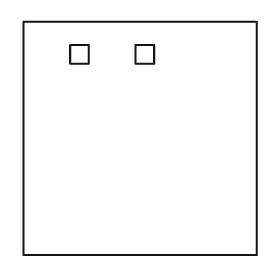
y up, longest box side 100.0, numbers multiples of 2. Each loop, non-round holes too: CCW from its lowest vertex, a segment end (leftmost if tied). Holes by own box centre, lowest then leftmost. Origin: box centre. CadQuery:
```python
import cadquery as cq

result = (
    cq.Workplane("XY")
    .moveTo(-50.0, -50.0)
    .lineTo(50.0, -50.0)
    .lineTo(50.0, 50.0)
    .lineTo(-50.0, 50.0)
    .close()
    .moveTo(-30.0, 32.0)
    .lineTo(-22.0, 32.0)
    .lineTo(-22.0, 40.0)
    .lineTo(-30.0, 40.0)
    .close()
    .moveTo(-2.0, 32.0)
    .lineTo(6.0, 32.0)
    .lineTo(6.0, 40.0)
    .lineTo(-2.0, 40.0)
    .close()
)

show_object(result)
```